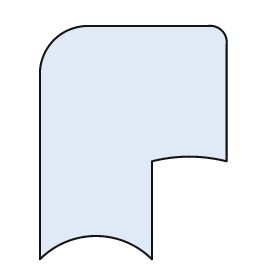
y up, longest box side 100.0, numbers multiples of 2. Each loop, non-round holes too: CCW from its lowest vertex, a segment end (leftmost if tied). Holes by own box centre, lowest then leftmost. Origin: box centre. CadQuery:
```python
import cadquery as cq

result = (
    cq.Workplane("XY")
    .moveTo(-40.0, -50.0)
    .threePointArc((-16.0, -40.0), (8.0, -50.0))
    .lineTo(8.0, -8.0)
    .threePointArc((24.0, -6.0), (40.0, -8.0))
    .lineTo(40.0, 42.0)
    .threePointArc((38.0, 48.0), (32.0, 50.0))
    .lineTo(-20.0, 50.0)
    .threePointArc((-34.0, 44.0), (-40.0, 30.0))
    .close()
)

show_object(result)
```